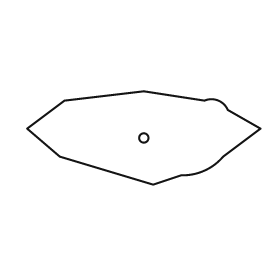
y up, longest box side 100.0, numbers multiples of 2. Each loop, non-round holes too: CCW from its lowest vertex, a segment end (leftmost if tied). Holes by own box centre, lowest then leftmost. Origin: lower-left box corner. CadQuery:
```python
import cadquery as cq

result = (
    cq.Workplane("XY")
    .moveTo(54.0, 0.0)
    .lineTo(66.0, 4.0)
    .threePointArc((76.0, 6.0), (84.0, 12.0))
    .lineTo(100.0, 24.0)
    .lineTo(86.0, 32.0)
    .threePointArc((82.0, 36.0), (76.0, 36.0))
    .lineTo(50.0, 40.0)
    .lineTo(16.0, 36.0)
    .lineTo(0.0, 24.0)
    .lineTo(14.0, 12.0)
    .close()
    .moveTo(50.0, 20.0)
    .circle(2.0)
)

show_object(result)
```